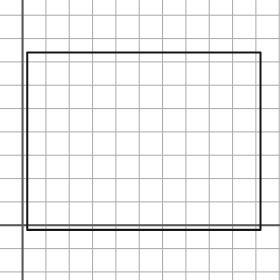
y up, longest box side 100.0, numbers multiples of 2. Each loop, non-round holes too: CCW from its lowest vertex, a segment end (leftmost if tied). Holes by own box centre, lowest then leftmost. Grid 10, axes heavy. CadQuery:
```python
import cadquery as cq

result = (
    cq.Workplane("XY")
    .moveTo(2.0, -2.0)
    .lineTo(102.0, -2.0)
    .lineTo(102.0, 74.0)
    .lineTo(2.0, 74.0)
    .close()
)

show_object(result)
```